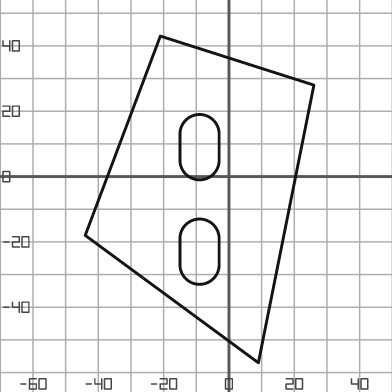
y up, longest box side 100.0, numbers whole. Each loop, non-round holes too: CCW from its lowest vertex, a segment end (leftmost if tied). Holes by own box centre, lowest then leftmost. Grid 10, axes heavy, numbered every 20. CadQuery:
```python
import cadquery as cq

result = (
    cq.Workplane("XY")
    .moveTo(9.0, -57.0)
    .lineTo(26.0, 28.0)
    .lineTo(-21.0, 43.0)
    .lineTo(-44.0, -18.0)
    .close()
    .moveTo(-15.0, -27.0)
    .threePointArc((-9.0, -33.0), (-3.0, -27.0))
    .lineTo(-3.0, -19.0)
    .threePointArc((-9.0, -13.0), (-15.0, -19.0))
    .close()
    .moveTo(-15.0, 5.0)
    .threePointArc((-9.0, -1.0), (-3.0, 5.0))
    .lineTo(-3.0, 13.0)
    .threePointArc((-9.0, 19.0), (-15.0, 13.0))
    .close()
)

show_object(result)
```